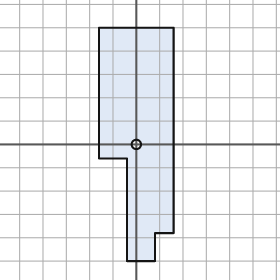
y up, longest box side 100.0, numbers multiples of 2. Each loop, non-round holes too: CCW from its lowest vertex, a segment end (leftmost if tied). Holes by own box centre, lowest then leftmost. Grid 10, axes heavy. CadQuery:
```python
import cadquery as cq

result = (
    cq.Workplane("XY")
    .moveTo(-4.0, -50.0)
    .lineTo(8.0, -50.0)
    .lineTo(8.0, -38.0)
    .lineTo(16.0, -38.0)
    .lineTo(16.0, 50.0)
    .lineTo(-16.0, 50.0)
    .lineTo(-16.0, -6.0)
    .lineTo(-4.0, -6.0)
    .close()
    .moveTo(0.0, 0.0)
    .circle(2.0)
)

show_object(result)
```